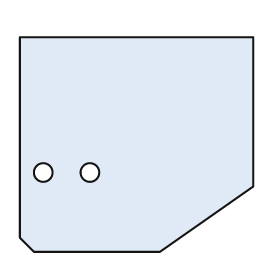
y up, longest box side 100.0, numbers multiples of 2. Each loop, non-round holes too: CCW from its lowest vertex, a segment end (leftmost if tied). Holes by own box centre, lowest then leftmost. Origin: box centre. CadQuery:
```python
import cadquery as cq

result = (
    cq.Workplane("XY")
    .moveTo(-44.0, -46.0)
    .lineTo(10.0, -46.0)
    .lineTo(50.0, -18.0)
    .lineTo(50.0, 46.0)
    .lineTo(-50.0, 46.0)
    .lineTo(-50.0, -40.0)
    .close()
    .moveTo(-40.0, -12.0)
    .circle(4.0)
    .moveTo(-20.0, -12.0)
    .circle(4.0)
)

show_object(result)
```